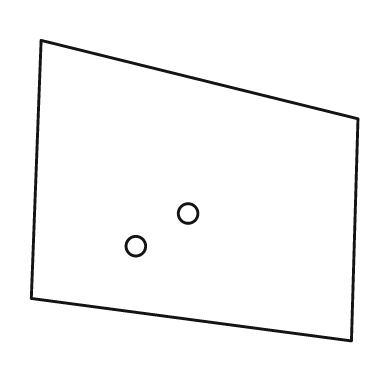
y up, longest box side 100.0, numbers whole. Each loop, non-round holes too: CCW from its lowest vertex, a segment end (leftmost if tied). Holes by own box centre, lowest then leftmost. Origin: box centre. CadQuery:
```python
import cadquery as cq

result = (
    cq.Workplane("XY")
    .moveTo(48.0, -46.0)
    .lineTo(50.0, 22.0)
    .lineTo(-47.0, 46.0)
    .lineTo(-50.0, -33.0)
    .close()
    .moveTo(-18.0, -17.0)
    .circle(3.0)
    .moveTo(-2.0, -7.0)
    .circle(3.0)
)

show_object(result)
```